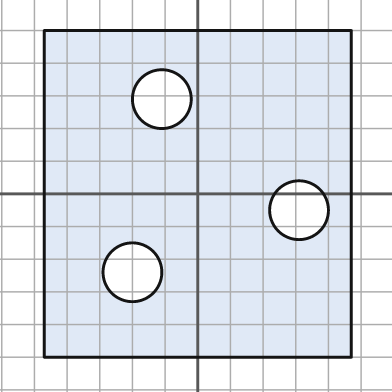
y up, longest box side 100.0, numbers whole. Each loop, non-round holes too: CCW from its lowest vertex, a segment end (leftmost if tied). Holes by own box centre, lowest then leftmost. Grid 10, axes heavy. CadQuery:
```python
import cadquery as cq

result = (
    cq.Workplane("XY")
    .moveTo(-47.0, -50.0)
    .lineTo(47.0, -50.0)
    .lineTo(47.0, 50.0)
    .lineTo(-47.0, 50.0)
    .close()
    .moveTo(-20.0, -24.0)
    .circle(9.0)
    .moveTo(31.0, -5.0)
    .circle(9.0)
    .moveTo(-11.0, 29.0)
    .circle(9.0)
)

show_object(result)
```